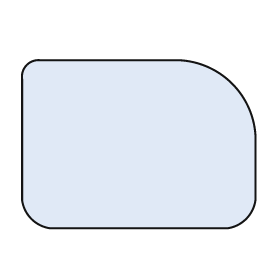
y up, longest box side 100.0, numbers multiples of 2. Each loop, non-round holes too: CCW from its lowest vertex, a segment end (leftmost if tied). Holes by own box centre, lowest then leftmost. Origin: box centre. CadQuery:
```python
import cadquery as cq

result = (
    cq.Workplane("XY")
    .moveTo(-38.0, -36.0)
    .lineTo(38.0, -36.0)
    .threePointArc((46.0, -32.0), (50.0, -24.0))
    .lineTo(50.0, 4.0)
    .threePointArc((40.0, 26.0), (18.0, 36.0))
    .lineTo(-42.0, 36.0)
    .threePointArc((-48.0, 34.0), (-50.0, 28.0))
    .lineTo(-50.0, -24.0)
    .threePointArc((-46.0, -32.0), (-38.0, -36.0))
    .close()
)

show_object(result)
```